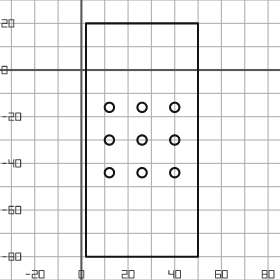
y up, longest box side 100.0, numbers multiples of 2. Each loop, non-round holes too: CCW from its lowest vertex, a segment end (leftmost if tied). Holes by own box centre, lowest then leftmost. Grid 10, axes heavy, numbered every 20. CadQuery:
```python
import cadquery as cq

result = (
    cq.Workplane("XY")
    .moveTo(2.0, -80.0)
    .lineTo(50.0, -80.0)
    .lineTo(50.0, 20.0)
    .lineTo(2.0, 20.0)
    .close()
    .moveTo(12.0, -44.0)
    .circle(2.0)
    .moveTo(26.0, -44.0)
    .circle(2.0)
    .moveTo(40.0, -44.0)
    .circle(2.0)
    .moveTo(12.0, -30.0)
    .circle(2.0)
    .moveTo(26.0, -30.0)
    .circle(2.0)
    .moveTo(40.0, -30.0)
    .circle(2.0)
    .moveTo(12.0, -16.0)
    .circle(2.0)
    .moveTo(26.0, -16.0)
    .circle(2.0)
    .moveTo(40.0, -16.0)
    .circle(2.0)
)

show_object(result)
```